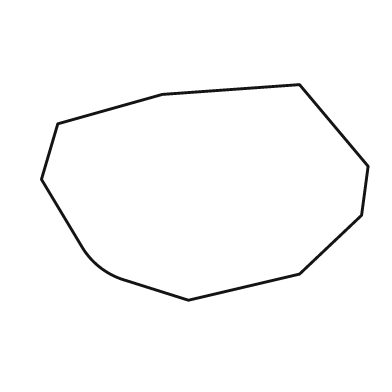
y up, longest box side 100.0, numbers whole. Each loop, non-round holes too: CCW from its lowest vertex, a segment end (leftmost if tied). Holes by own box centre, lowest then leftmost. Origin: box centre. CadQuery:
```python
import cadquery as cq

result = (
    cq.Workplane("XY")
    .moveTo(-5.0, -33.0)
    .lineTo(29.0, -25.0)
    .lineTo(48.0, -7.0)
    .lineTo(50.0, 8.0)
    .lineTo(29.0, 33.0)
    .lineTo(-13.0, 30.0)
    .lineTo(-45.0, 21.0)
    .lineTo(-50.0, 4.0)
    .lineTo(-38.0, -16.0)
    .threePointArc((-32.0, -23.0), (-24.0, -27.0))
    .close()
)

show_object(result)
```